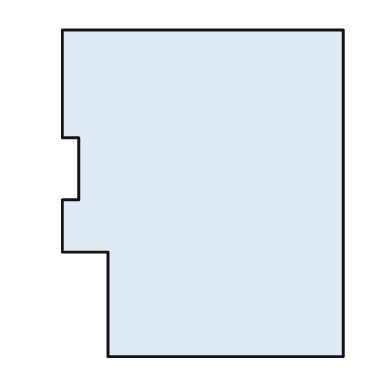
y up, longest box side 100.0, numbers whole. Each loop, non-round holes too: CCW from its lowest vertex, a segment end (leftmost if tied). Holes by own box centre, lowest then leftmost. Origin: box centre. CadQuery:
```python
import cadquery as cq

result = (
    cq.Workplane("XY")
    .moveTo(-29.0, -50.0)
    .lineTo(43.0, -50.0)
    .lineTo(43.0, 50.0)
    .lineTo(-43.0, 50.0)
    .lineTo(-43.0, 17.0)
    .lineTo(-38.0, 17.0)
    .lineTo(-38.0, -2.0)
    .lineTo(-43.0, -2.0)
    .lineTo(-43.0, -18.0)
    .lineTo(-29.0, -18.0)
    .close()
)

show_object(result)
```